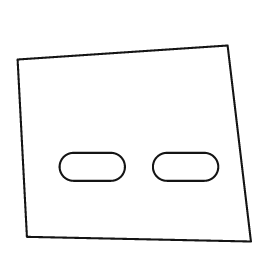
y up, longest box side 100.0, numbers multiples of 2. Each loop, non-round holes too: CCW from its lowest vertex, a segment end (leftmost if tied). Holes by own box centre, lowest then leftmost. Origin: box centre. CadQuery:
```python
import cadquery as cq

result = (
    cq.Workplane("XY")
    .moveTo(50.0, -42.0)
    .lineTo(40.0, 42.0)
    .lineTo(-50.0, 36.0)
    .lineTo(-46.0, -40.0)
    .close()
    .moveTo(-26.0, -16.0)
    .lineTo(-10.0, -16.0)
    .threePointArc((-4.0, -10.0), (-10.0, -4.0))
    .lineTo(-26.0, -4.0)
    .threePointArc((-32.0, -10.0), (-26.0, -16.0))
    .close()
    .moveTo(14.0, -16.0)
    .lineTo(30.0, -16.0)
    .threePointArc((36.0, -10.0), (30.0, -4.0))
    .lineTo(14.0, -4.0)
    .threePointArc((8.0, -10.0), (14.0, -16.0))
    .close()
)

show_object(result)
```